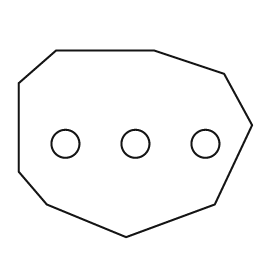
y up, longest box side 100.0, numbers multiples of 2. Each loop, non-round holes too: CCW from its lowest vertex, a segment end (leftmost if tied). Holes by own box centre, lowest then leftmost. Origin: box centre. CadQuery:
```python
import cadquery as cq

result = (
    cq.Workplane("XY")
    .moveTo(-4.0, -40.0)
    .lineTo(34.0, -26.0)
    .lineTo(50.0, 8.0)
    .lineTo(38.0, 30.0)
    .lineTo(8.0, 40.0)
    .lineTo(-34.0, 40.0)
    .lineTo(-50.0, 26.0)
    .lineTo(-50.0, -12.0)
    .lineTo(-38.0, -26.0)
    .close()
    .moveTo(-30.0, 0.0)
    .circle(6.0)
    .moveTo(0.0, 0.0)
    .circle(6.0)
    .moveTo(30.0, 0.0)
    .circle(6.0)
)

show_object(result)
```